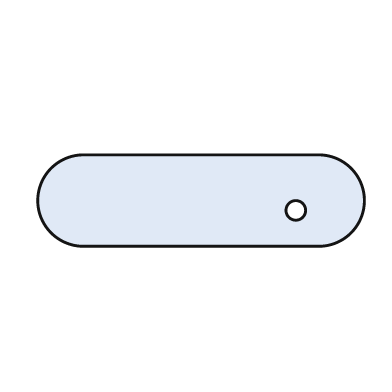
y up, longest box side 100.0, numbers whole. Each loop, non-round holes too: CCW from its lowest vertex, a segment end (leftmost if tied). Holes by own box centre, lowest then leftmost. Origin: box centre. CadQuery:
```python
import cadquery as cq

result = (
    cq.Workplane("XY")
    .moveTo(-36.0, -14.0)
    .lineTo(36.0, -14.0)
    .threePointArc((50.0, 0.0), (36.0, 14.0))
    .lineTo(-36.0, 14.0)
    .threePointArc((-50.0, 0.0), (-36.0, -14.0))
    .close()
    .moveTo(29.0, -3.0)
    .circle(3.0)
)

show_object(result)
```